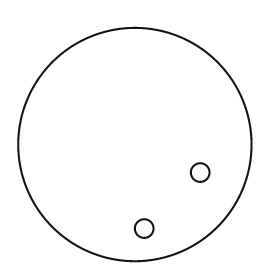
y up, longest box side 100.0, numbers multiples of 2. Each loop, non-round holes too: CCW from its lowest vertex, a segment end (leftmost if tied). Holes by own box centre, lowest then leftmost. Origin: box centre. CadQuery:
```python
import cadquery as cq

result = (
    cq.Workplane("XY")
    .moveTo(0.0, 0.0)
    .circle(50.0)
    .moveTo(4.0, -36.0)
    .circle(4.0)
    .moveTo(28.0, -12.0)
    .circle(4.0)
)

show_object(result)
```